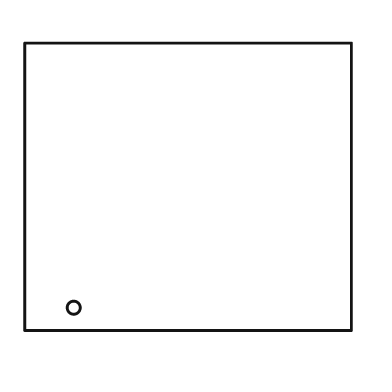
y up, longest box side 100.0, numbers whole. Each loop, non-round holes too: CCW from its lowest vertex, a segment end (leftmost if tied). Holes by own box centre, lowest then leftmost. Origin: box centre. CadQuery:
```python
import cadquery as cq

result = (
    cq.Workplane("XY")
    .moveTo(-50.0, -44.0)
    .lineTo(50.0, -44.0)
    .lineTo(50.0, 44.0)
    .lineTo(-50.0, 44.0)
    .close()
    .moveTo(-35.0, -37.0)
    .circle(2.0)
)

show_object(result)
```